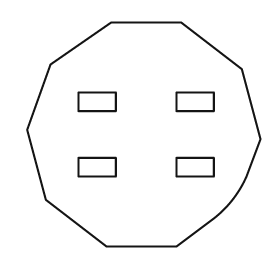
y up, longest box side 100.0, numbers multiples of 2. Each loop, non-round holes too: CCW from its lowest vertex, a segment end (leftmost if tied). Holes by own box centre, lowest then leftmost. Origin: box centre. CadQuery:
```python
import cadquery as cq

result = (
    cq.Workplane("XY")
    .moveTo(-16.0, -48.0)
    .lineTo(14.0, -48.0)
    .lineTo(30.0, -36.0)
    .threePointArc((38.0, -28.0), (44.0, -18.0))
    .lineTo(50.0, -2.0)
    .lineTo(42.0, 28.0)
    .lineTo(16.0, 48.0)
    .lineTo(-14.0, 48.0)
    .lineTo(-40.0, 30.0)
    .lineTo(-50.0, 2.0)
    .lineTo(-42.0, -28.0)
    .close()
    .moveTo(-28.0, -18.0)
    .lineTo(-12.0, -18.0)
    .lineTo(-12.0, -10.0)
    .lineTo(-28.0, -10.0)
    .close()
    .moveTo(14.0, -18.0)
    .lineTo(30.0, -18.0)
    .lineTo(30.0, -10.0)
    .lineTo(14.0, -10.0)
    .close()
    .moveTo(-28.0, 10.0)
    .lineTo(-12.0, 10.0)
    .lineTo(-12.0, 18.0)
    .lineTo(-28.0, 18.0)
    .close()
    .moveTo(14.0, 10.0)
    .lineTo(30.0, 10.0)
    .lineTo(30.0, 18.0)
    .lineTo(14.0, 18.0)
    .close()
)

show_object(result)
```